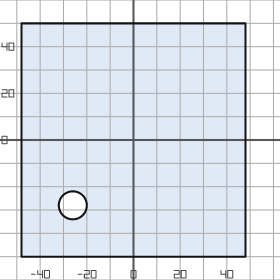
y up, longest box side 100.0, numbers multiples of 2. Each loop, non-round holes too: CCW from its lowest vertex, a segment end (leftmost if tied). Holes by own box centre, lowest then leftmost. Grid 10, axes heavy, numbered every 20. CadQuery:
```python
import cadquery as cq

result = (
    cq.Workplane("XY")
    .moveTo(-48.0, -50.0)
    .lineTo(48.0, -50.0)
    .lineTo(48.0, 50.0)
    .lineTo(-48.0, 50.0)
    .close()
    .moveTo(-26.0, -28.0)
    .circle(6.0)
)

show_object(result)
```